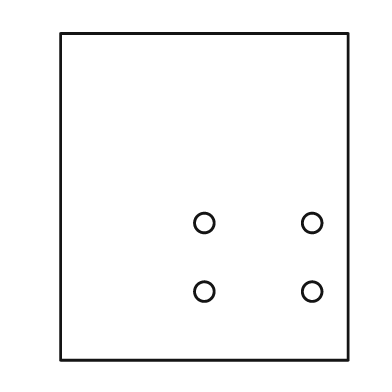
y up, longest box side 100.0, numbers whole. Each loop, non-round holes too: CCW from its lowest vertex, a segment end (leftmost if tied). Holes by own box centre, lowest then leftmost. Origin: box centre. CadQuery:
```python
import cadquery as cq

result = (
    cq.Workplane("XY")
    .moveTo(-44.0, -50.0)
    .lineTo(44.0, -50.0)
    .lineTo(44.0, 50.0)
    .lineTo(-44.0, 50.0)
    .close()
    .moveTo(0.0, -29.0)
    .circle(3.0)
    .moveTo(33.0, -29.0)
    .circle(3.0)
    .moveTo(0.0, -8.0)
    .circle(3.0)
    .moveTo(33.0, -8.0)
    .circle(3.0)
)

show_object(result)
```